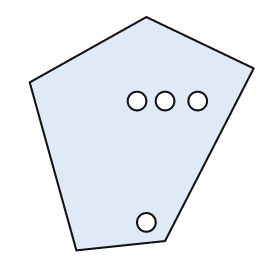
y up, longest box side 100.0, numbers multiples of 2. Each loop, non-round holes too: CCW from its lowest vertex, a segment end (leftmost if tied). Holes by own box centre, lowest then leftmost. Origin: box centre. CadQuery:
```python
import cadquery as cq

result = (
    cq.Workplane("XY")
    .moveTo(-28.0, -50.0)
    .lineTo(10.0, -46.0)
    .lineTo(48.0, 28.0)
    .lineTo(2.0, 50.0)
    .lineTo(-48.0, 22.0)
    .close()
    .moveTo(2.0, -38.0)
    .circle(4.0)
    .moveTo(-2.0, 14.0)
    .circle(4.0)
    .moveTo(10.0, 14.0)
    .circle(4.0)
    .moveTo(24.0, 14.0)
    .circle(4.0)
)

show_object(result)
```